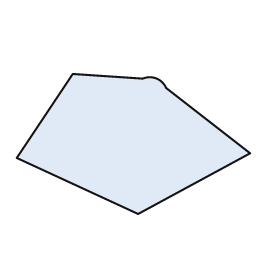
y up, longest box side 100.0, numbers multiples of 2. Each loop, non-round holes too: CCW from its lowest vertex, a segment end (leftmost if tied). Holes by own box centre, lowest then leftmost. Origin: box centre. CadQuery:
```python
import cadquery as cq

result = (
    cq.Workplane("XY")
    .moveTo(2.0, -30.0)
    .lineTo(50.0, -4.0)
    .lineTo(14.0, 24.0)
    .threePointArc((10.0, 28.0), (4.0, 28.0))
    .lineTo(-26.0, 30.0)
    .lineTo(-50.0, -6.0)
    .close()
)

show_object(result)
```